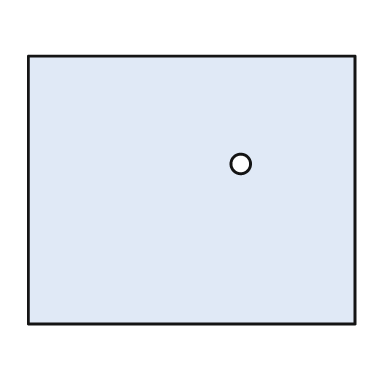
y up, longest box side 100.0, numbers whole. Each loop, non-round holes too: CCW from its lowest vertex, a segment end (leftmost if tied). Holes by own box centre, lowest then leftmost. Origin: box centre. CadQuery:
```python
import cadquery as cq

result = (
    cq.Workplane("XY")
    .moveTo(-50.0, -41.0)
    .lineTo(50.0, -41.0)
    .lineTo(50.0, 41.0)
    .lineTo(-50.0, 41.0)
    .close()
    .moveTo(15.0, 8.0)
    .circle(3.0)
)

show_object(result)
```